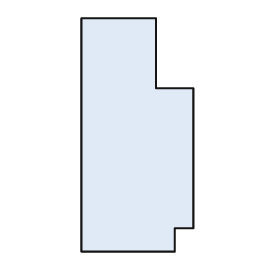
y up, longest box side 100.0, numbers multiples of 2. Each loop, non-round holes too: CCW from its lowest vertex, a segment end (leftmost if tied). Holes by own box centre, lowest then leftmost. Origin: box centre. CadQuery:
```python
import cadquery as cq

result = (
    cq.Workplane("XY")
    .moveTo(-24.0, -50.0)
    .lineTo(16.0, -50.0)
    .lineTo(16.0, -40.0)
    .lineTo(24.0, -40.0)
    .lineTo(24.0, 20.0)
    .lineTo(8.0, 20.0)
    .lineTo(8.0, 50.0)
    .lineTo(-24.0, 50.0)
    .close()
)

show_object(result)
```